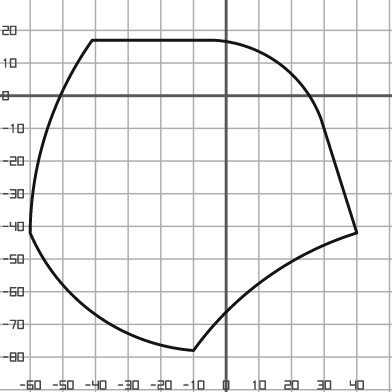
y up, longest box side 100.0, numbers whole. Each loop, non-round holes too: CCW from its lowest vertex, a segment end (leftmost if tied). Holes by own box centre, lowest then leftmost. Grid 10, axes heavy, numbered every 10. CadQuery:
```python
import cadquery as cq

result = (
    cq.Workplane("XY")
    .moveTo(-10.0, -78.0)
    .threePointArc((12.0, -56.0), (40.0, -42.0))
    .lineTo(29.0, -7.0)
    .threePointArc((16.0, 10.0), (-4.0, 17.0))
    .lineTo(-41.0, 17.0)
    .threePointArc((-55.0, -11.0), (-60.0, -42.0))
    .threePointArc((-40.0, -67.0), (-10.0, -78.0))
    .close()
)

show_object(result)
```